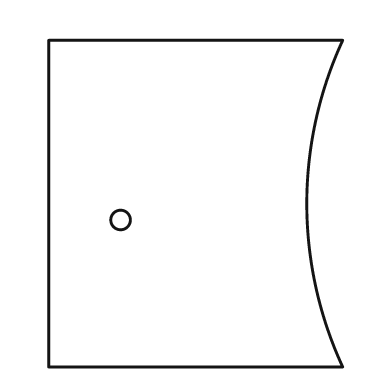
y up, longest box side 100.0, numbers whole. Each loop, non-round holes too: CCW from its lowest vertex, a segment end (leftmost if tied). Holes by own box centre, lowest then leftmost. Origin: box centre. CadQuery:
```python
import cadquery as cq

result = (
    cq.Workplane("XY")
    .moveTo(-45.0, -50.0)
    .lineTo(45.0, -50.0)
    .threePointArc((34.0, 0.0), (45.0, 50.0))
    .lineTo(-45.0, 50.0)
    .close()
    .moveTo(-23.0, -5.0)
    .circle(3.0)
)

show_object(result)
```